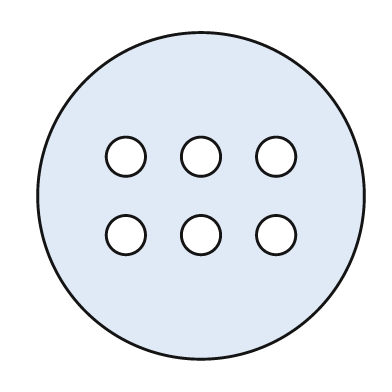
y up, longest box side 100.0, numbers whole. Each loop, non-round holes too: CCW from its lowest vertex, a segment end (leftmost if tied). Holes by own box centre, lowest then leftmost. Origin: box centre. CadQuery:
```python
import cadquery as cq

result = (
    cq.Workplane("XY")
    .moveTo(0.0, 0.0)
    .circle(50.0)
    .moveTo(-23.0, -12.0)
    .circle(6.0)
    .moveTo(0.0, -12.0)
    .circle(6.0)
    .moveTo(23.0, -12.0)
    .circle(6.0)
    .moveTo(-23.0, 12.0)
    .circle(6.0)
    .moveTo(0.0, 12.0)
    .circle(6.0)
    .moveTo(23.0, 12.0)
    .circle(6.0)
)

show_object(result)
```